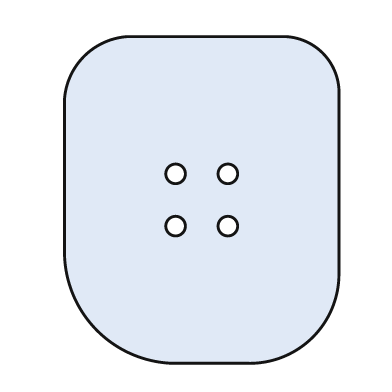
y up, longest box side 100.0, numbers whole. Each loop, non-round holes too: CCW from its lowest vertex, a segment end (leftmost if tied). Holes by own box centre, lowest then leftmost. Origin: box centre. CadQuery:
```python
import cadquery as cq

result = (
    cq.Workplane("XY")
    .moveTo(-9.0, -50.0)
    .lineTo(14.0, -50.0)
    .threePointArc((34.0, -42.0), (42.0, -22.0))
    .lineTo(42.0, 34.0)
    .threePointArc((37.0, 45.0), (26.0, 50.0))
    .lineTo(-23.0, 50.0)
    .threePointArc((-36.0, 44.0), (-42.0, 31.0))
    .lineTo(-42.0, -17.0)
    .threePointArc((-32.0, -40.0), (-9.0, -50.0))
    .close()
    .moveTo(-8.0, -8.0)
    .circle(3.0)
    .moveTo(8.0, -8.0)
    .circle(3.0)
    .moveTo(-8.0, 8.0)
    .circle(3.0)
    .moveTo(8.0, 8.0)
    .circle(3.0)
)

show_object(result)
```